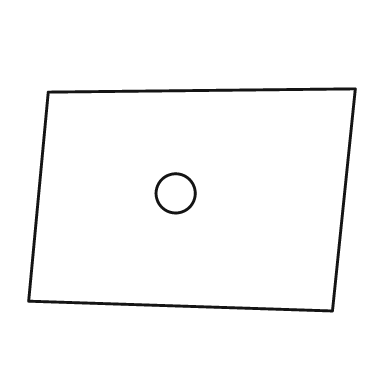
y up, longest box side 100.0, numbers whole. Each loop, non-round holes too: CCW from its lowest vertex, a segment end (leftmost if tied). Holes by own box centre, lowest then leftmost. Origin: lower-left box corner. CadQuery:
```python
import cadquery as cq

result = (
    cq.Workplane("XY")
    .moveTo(93.0, 0.0)
    .lineTo(100.0, 68.0)
    .lineTo(6.0, 67.0)
    .lineTo(0.0, 3.0)
    .close()
    .moveTo(45.0, 36.0)
    .circle(6.0)
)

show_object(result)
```